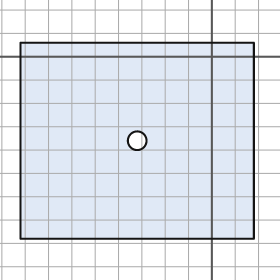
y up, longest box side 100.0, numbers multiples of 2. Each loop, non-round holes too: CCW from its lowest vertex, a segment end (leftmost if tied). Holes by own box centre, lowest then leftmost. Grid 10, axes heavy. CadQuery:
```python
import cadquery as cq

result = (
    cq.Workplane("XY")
    .moveTo(-82.0, -78.0)
    .lineTo(18.0, -78.0)
    .lineTo(18.0, 6.0)
    .lineTo(-82.0, 6.0)
    .close()
    .moveTo(-32.0, -36.0)
    .circle(4.0)
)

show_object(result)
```